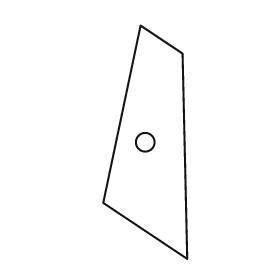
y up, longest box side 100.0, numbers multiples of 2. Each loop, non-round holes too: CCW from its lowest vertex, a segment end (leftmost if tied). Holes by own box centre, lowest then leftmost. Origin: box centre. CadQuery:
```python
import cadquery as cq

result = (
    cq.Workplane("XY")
    .moveTo(18.0, -50.0)
    .lineTo(16.0, 38.0)
    .lineTo(-2.0, 50.0)
    .lineTo(-18.0, -26.0)
    .close()
    .moveTo(0.0, 0.0)
    .circle(4.0)
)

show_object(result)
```